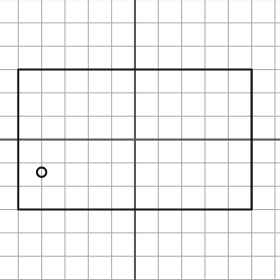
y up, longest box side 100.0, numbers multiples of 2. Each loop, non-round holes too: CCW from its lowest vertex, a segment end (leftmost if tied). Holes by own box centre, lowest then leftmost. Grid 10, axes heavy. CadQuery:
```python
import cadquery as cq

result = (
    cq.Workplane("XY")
    .moveTo(-50.0, -30.0)
    .lineTo(50.0, -30.0)
    .lineTo(50.0, 30.0)
    .lineTo(-50.0, 30.0)
    .close()
    .moveTo(-40.0, -14.0)
    .circle(2.0)
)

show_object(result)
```